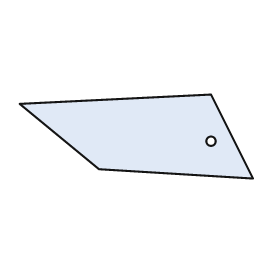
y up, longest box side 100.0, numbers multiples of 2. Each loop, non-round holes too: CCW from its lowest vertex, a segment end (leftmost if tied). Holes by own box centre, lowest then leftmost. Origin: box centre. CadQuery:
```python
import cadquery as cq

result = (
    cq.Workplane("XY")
    .moveTo(50.0, -18.0)
    .lineTo(32.0, 18.0)
    .lineTo(-50.0, 14.0)
    .lineTo(-16.0, -14.0)
    .close()
    .moveTo(32.0, -2.0)
    .circle(2.0)
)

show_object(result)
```